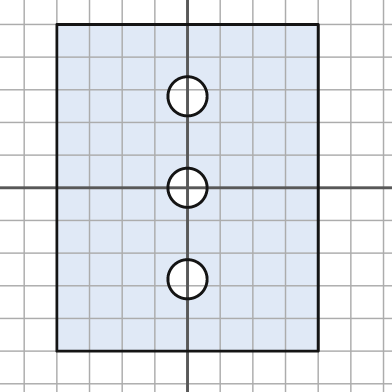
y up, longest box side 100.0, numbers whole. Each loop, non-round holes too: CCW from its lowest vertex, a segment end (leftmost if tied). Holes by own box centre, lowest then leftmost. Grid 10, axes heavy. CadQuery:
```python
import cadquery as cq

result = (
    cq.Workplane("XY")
    .moveTo(-40.0, -50.0)
    .lineTo(40.0, -50.0)
    .lineTo(40.0, 50.0)
    .lineTo(-40.0, 50.0)
    .close()
    .moveTo(0.0, -28.0)
    .circle(6.0)
    .moveTo(0.0, 0.0)
    .circle(6.0)
    .moveTo(0.0, 28.0)
    .circle(6.0)
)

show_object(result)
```